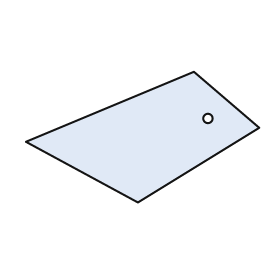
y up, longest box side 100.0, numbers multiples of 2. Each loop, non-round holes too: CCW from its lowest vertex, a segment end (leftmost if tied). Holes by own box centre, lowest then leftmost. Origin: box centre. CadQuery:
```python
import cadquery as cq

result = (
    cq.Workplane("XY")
    .moveTo(-2.0, -28.0)
    .lineTo(50.0, 4.0)
    .lineTo(22.0, 28.0)
    .lineTo(-50.0, -2.0)
    .close()
    .moveTo(28.0, 8.0)
    .circle(2.0)
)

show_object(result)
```